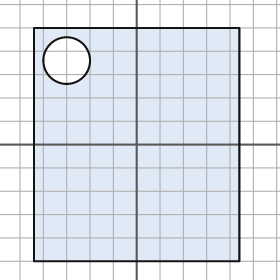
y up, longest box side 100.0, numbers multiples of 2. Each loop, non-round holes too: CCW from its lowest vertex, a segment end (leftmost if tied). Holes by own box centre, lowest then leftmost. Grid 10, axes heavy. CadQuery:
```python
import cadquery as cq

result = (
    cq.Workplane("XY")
    .moveTo(-44.0, -50.0)
    .lineTo(44.0, -50.0)
    .lineTo(44.0, 50.0)
    .lineTo(-44.0, 50.0)
    .close()
    .moveTo(-30.0, 36.0)
    .circle(10.0)
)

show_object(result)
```